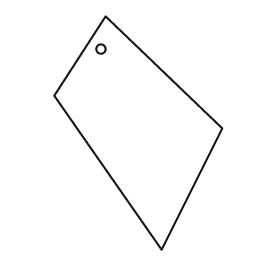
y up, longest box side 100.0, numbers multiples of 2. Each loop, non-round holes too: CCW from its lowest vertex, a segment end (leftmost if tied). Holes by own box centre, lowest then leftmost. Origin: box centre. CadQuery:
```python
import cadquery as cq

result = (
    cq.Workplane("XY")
    .moveTo(10.0, -50.0)
    .lineTo(36.0, 2.0)
    .lineTo(-14.0, 50.0)
    .lineTo(-36.0, 16.0)
    .close()
    .moveTo(-16.0, 36.0)
    .circle(2.0)
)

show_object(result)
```